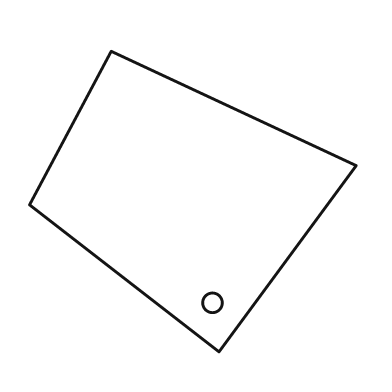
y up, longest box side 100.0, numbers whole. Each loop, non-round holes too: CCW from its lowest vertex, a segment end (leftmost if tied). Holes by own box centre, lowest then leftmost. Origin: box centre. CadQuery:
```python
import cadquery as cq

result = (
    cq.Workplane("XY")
    .moveTo(8.0, -46.0)
    .lineTo(50.0, 11.0)
    .lineTo(-25.0, 46.0)
    .lineTo(-50.0, -1.0)
    .close()
    .moveTo(6.0, -31.0)
    .circle(3.0)
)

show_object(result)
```